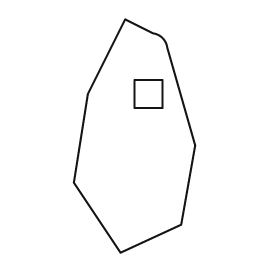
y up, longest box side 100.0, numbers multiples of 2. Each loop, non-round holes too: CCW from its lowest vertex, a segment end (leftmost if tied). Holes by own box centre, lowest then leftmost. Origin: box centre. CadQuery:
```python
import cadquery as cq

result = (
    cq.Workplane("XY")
    .moveTo(-6.0, -50.0)
    .lineTo(20.0, -38.0)
    .lineTo(26.0, -4.0)
    .lineTo(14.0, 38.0)
    .threePointArc((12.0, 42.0), (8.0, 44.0))
    .lineTo(-4.0, 50.0)
    .lineTo(-20.0, 18.0)
    .lineTo(-26.0, -20.0)
    .close()
    .moveTo(0.0, 12.0)
    .lineTo(12.0, 12.0)
    .lineTo(12.0, 24.0)
    .lineTo(0.0, 24.0)
    .close()
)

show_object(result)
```